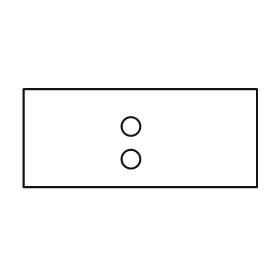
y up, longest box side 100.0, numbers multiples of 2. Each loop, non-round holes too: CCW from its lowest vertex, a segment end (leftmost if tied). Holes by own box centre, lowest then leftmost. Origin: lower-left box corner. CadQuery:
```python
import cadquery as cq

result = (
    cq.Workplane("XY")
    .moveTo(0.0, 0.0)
    .lineTo(100.0, 0.0)
    .lineTo(100.0, 42.0)
    .lineTo(0.0, 42.0)
    .close()
    .moveTo(46.0, 12.0)
    .circle(4.0)
    .moveTo(46.0, 26.0)
    .circle(4.0)
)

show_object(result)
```